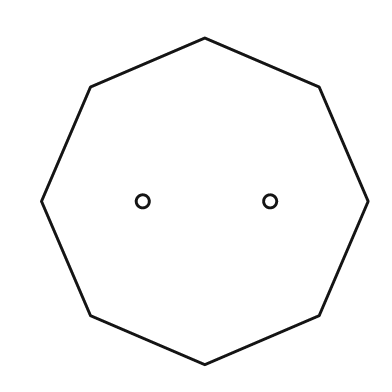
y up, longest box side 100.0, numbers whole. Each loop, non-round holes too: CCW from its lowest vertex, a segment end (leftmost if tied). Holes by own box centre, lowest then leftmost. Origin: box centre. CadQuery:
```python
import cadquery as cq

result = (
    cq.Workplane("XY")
    .moveTo(0.0, -50.0)
    .lineTo(35.0, -35.0)
    .lineTo(50.0, 0.0)
    .lineTo(35.0, 35.0)
    .lineTo(0.0, 50.0)
    .lineTo(-35.0, 35.0)
    .lineTo(-50.0, 0.0)
    .lineTo(-35.0, -35.0)
    .close()
    .moveTo(-19.0, 0.0)
    .circle(2.0)
    .moveTo(20.0, 0.0)
    .circle(2.0)
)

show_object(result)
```